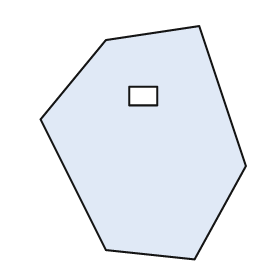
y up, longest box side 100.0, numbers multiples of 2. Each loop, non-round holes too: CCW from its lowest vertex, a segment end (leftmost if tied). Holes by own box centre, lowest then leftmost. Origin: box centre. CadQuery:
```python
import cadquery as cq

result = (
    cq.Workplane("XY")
    .moveTo(22.0, -50.0)
    .lineTo(44.0, -10.0)
    .lineTo(24.0, 50.0)
    .lineTo(-16.0, 44.0)
    .lineTo(-44.0, 10.0)
    .lineTo(-16.0, -46.0)
    .close()
    .moveTo(-6.0, 16.0)
    .lineTo(6.0, 16.0)
    .lineTo(6.0, 24.0)
    .lineTo(-6.0, 24.0)
    .close()
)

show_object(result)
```